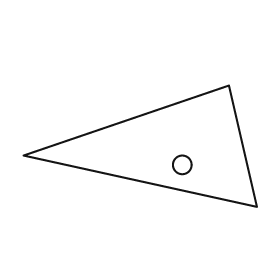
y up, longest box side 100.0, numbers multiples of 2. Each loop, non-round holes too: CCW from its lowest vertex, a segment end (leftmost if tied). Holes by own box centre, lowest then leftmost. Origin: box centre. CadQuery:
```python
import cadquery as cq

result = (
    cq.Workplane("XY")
    .moveTo(50.0, -26.0)
    .lineTo(38.0, 26.0)
    .lineTo(-50.0, -4.0)
    .close()
    .moveTo(18.0, -8.0)
    .circle(4.0)
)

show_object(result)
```